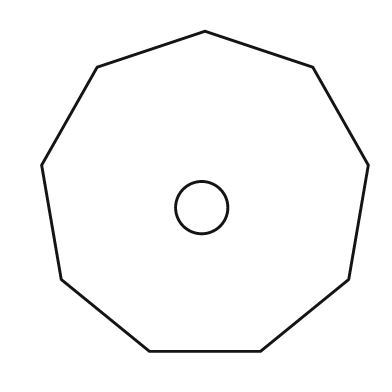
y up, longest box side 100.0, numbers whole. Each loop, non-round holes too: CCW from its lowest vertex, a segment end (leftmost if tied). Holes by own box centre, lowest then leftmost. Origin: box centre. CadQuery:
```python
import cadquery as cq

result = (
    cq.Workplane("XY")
    .moveTo(-17.0, -49.0)
    .lineTo(17.0, -49.0)
    .lineTo(44.0, -27.0)
    .lineTo(50.0, 8.0)
    .lineTo(33.0, 38.0)
    .lineTo(0.0, 49.0)
    .lineTo(-33.0, 38.0)
    .lineTo(-50.0, 8.0)
    .lineTo(-44.0, -27.0)
    .close()
    .moveTo(-1.0, -5.0)
    .circle(8.0)
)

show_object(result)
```